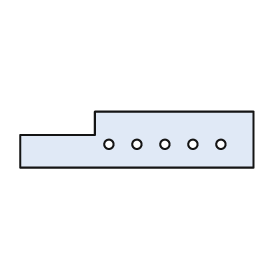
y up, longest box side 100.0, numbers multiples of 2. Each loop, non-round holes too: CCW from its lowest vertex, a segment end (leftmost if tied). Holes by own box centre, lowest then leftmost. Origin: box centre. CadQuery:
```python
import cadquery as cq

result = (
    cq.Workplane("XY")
    .moveTo(-50.0, -12.0)
    .lineTo(50.0, -12.0)
    .lineTo(50.0, 12.0)
    .lineTo(-18.0, 12.0)
    .lineTo(-18.0, 2.0)
    .lineTo(-50.0, 2.0)
    .close()
    .moveTo(-12.0, -2.0)
    .circle(2.0)
    .moveTo(0.0, -2.0)
    .circle(2.0)
    .moveTo(12.0, -2.0)
    .circle(2.0)
    .moveTo(24.0, -2.0)
    .circle(2.0)
    .moveTo(36.0, -2.0)
    .circle(2.0)
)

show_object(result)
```